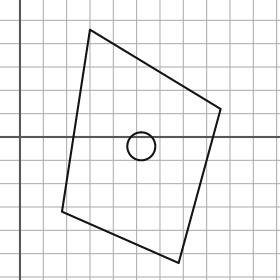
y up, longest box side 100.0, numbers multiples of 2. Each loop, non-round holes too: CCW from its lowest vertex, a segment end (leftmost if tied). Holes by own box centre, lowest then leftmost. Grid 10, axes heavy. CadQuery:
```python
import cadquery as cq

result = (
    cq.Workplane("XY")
    .moveTo(68.0, -54.0)
    .lineTo(86.0, 12.0)
    .lineTo(30.0, 46.0)
    .lineTo(18.0, -32.0)
    .close()
    .moveTo(52.0, -4.0)
    .circle(6.0)
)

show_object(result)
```